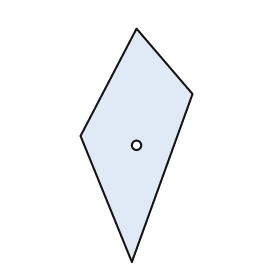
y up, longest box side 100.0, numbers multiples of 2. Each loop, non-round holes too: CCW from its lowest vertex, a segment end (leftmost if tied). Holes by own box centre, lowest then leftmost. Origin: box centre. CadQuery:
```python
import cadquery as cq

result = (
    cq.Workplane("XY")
    .moveTo(-2.0, -50.0)
    .lineTo(24.0, 22.0)
    .lineTo(0.0, 50.0)
    .lineTo(-24.0, 4.0)
    .close()
    .moveTo(0.0, 0.0)
    .circle(2.0)
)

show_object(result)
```